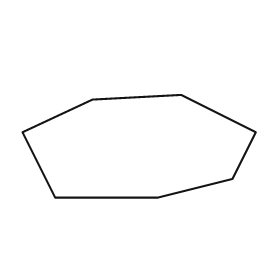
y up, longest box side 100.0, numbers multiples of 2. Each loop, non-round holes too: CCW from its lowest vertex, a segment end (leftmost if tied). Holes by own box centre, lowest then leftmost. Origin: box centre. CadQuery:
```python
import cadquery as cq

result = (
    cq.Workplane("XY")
    .moveTo(-36.0, -22.0)
    .lineTo(8.0, -22.0)
    .lineTo(40.0, -14.0)
    .lineTo(50.0, 6.0)
    .lineTo(18.0, 22.0)
    .lineTo(-20.0, 20.0)
    .lineTo(-50.0, 6.0)
    .close()
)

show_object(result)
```